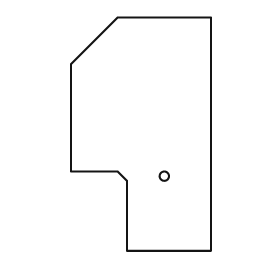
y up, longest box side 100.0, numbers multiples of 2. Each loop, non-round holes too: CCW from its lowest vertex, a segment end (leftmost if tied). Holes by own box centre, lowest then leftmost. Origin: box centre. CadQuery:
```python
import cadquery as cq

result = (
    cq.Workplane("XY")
    .moveTo(-6.0, -50.0)
    .lineTo(30.0, -50.0)
    .lineTo(30.0, 50.0)
    .lineTo(-10.0, 50.0)
    .lineTo(-30.0, 30.0)
    .lineTo(-30.0, -16.0)
    .lineTo(-10.0, -16.0)
    .lineTo(-6.0, -20.0)
    .close()
    .moveTo(10.0, -18.0)
    .circle(2.0)
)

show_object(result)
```